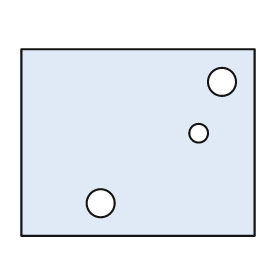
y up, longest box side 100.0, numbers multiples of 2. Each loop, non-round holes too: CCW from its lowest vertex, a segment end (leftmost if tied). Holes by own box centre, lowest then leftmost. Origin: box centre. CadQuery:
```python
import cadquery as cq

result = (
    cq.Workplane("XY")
    .moveTo(-50.0, -40.0)
    .lineTo(50.0, -40.0)
    .lineTo(50.0, 40.0)
    .lineTo(-50.0, 40.0)
    .close()
    .moveTo(-16.0, -26.0)
    .circle(6.0)
    .moveTo(26.0, 4.0)
    .circle(4.0)
    .moveTo(36.0, 26.0)
    .circle(6.0)
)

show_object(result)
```